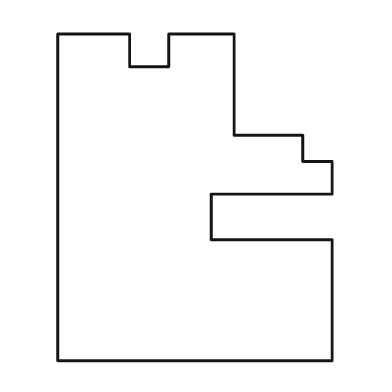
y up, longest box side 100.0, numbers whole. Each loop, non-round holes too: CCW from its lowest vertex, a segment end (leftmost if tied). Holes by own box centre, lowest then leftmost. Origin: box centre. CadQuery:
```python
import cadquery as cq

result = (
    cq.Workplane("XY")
    .moveTo(-42.0, -50.0)
    .lineTo(42.0, -50.0)
    .lineTo(42.0, -13.0)
    .lineTo(5.0, -13.0)
    .lineTo(5.0, 1.0)
    .lineTo(42.0, 1.0)
    .lineTo(42.0, 11.0)
    .lineTo(33.0, 11.0)
    .lineTo(33.0, 19.0)
    .lineTo(12.0, 19.0)
    .lineTo(12.0, 50.0)
    .lineTo(-8.0, 50.0)
    .lineTo(-8.0, 40.0)
    .lineTo(-20.0, 40.0)
    .lineTo(-20.0, 50.0)
    .lineTo(-42.0, 50.0)
    .close()
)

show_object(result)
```